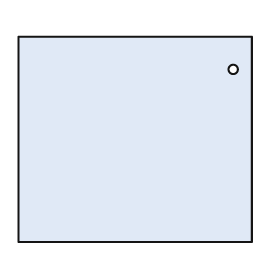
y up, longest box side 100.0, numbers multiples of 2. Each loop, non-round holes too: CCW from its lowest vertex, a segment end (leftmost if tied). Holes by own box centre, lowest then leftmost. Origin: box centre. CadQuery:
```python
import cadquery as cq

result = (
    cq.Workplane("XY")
    .moveTo(-50.0, -44.0)
    .lineTo(50.0, -44.0)
    .lineTo(50.0, 44.0)
    .lineTo(-50.0, 44.0)
    .close()
    .moveTo(42.0, 30.0)
    .circle(2.0)
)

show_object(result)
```